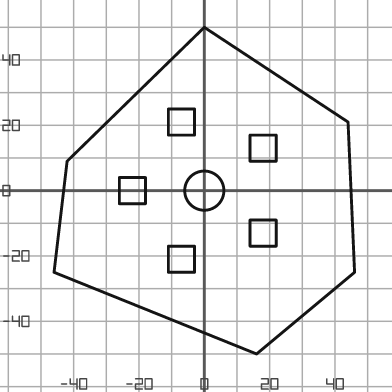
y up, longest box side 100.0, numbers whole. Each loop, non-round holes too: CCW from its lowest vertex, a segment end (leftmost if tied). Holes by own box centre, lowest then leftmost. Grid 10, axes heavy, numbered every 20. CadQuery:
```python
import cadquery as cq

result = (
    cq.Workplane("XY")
    .moveTo(16.0, -50.0)
    .lineTo(46.0, -25.0)
    .lineTo(44.0, 21.0)
    .lineTo(0.0, 50.0)
    .lineTo(-42.0, 9.0)
    .lineTo(-46.0, -25.0)
    .close()
    .moveTo(-11.0, -25.0)
    .lineTo(-3.0, -25.0)
    .lineTo(-3.0, -17.0)
    .lineTo(-11.0, -17.0)
    .close()
    .moveTo(14.0, -17.0)
    .lineTo(22.0, -17.0)
    .lineTo(22.0, -9.0)
    .lineTo(14.0, -9.0)
    .close()
    .moveTo(-26.0, -4.0)
    .lineTo(-18.0, -4.0)
    .lineTo(-18.0, 4.0)
    .lineTo(-26.0, 4.0)
    .close()
    .moveTo(0.0, 0.0)
    .circle(6.0)
    .moveTo(14.0, 9.0)
    .lineTo(22.0, 9.0)
    .lineTo(22.0, 17.0)
    .lineTo(14.0, 17.0)
    .close()
    .moveTo(-11.0, 17.0)
    .lineTo(-3.0, 17.0)
    .lineTo(-3.0, 25.0)
    .lineTo(-11.0, 25.0)
    .close()
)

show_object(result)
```